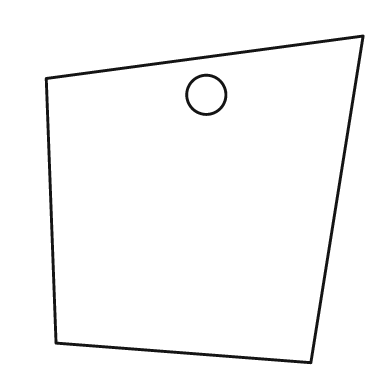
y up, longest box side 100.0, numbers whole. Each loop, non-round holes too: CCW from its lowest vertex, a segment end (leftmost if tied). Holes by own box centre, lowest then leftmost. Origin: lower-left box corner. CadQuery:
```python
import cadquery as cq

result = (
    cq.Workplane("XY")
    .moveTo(81.0, 0.0)
    .lineTo(97.0, 100.0)
    .lineTo(0.0, 87.0)
    .lineTo(3.0, 6.0)
    .close()
    .moveTo(49.0, 82.0)
    .circle(6.0)
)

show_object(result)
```